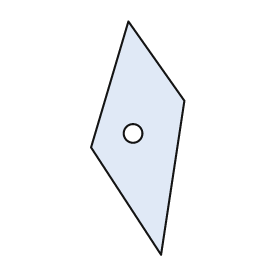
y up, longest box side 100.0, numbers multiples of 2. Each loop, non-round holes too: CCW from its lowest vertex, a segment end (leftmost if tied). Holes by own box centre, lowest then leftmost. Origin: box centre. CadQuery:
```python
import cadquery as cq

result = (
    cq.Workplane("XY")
    .moveTo(10.0, -50.0)
    .lineTo(20.0, 16.0)
    .lineTo(-4.0, 50.0)
    .lineTo(-20.0, -4.0)
    .close()
    .moveTo(-2.0, 2.0)
    .circle(4.0)
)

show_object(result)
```